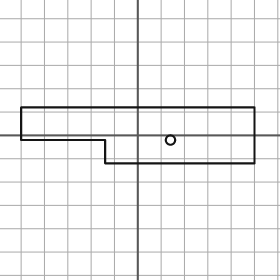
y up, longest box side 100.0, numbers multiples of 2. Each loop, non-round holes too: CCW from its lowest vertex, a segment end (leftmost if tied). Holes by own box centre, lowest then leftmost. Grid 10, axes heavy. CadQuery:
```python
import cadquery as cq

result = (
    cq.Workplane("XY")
    .moveTo(-14.0, -12.0)
    .lineTo(50.0, -12.0)
    .lineTo(50.0, 12.0)
    .lineTo(-50.0, 12.0)
    .lineTo(-50.0, -2.0)
    .lineTo(-14.0, -2.0)
    .close()
    .moveTo(14.0, -2.0)
    .circle(2.0)
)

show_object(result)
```